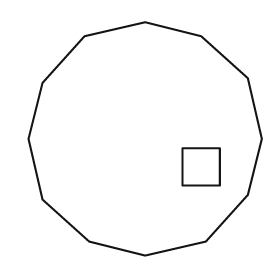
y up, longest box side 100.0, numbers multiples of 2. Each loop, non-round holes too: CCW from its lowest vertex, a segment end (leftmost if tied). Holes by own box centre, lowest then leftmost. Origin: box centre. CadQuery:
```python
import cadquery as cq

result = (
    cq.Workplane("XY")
    .moveTo(0.0, -50.0)
    .lineTo(26.0, -44.0)
    .lineTo(44.0, -24.0)
    .lineTo(50.0, 0.0)
    .lineTo(44.0, 26.0)
    .lineTo(24.0, 44.0)
    .lineTo(0.0, 50.0)
    .lineTo(-26.0, 44.0)
    .lineTo(-44.0, 24.0)
    .lineTo(-50.0, 0.0)
    .lineTo(-44.0, -26.0)
    .lineTo(-24.0, -44.0)
    .close()
    .moveTo(16.0, -20.0)
    .lineTo(32.0, -20.0)
    .lineTo(32.0, -4.0)
    .lineTo(16.0, -4.0)
    .close()
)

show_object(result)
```